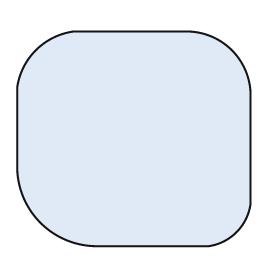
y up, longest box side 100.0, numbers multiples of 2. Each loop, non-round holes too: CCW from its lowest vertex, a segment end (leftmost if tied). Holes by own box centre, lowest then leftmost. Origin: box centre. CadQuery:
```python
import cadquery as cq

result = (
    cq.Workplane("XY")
    .moveTo(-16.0, -46.0)
    .lineTo(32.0, -46.0)
    .threePointArc((44.0, -40.0), (50.0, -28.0))
    .lineTo(50.0, 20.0)
    .threePointArc((42.0, 38.0), (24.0, 46.0))
    .lineTo(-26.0, 46.0)
    .threePointArc((-42.0, 38.0), (-50.0, 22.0))
    .lineTo(-50.0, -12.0)
    .threePointArc((-40.0, -36.0), (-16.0, -46.0))
    .close()
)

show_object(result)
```